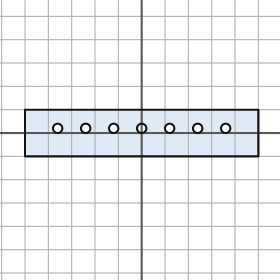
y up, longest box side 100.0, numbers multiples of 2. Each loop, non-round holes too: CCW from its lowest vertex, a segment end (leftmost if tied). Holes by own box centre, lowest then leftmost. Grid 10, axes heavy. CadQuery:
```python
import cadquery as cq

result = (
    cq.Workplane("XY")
    .moveTo(-50.0, -10.0)
    .lineTo(50.0, -10.0)
    .lineTo(50.0, 10.0)
    .lineTo(-50.0, 10.0)
    .close()
    .moveTo(-36.0, 2.0)
    .circle(2.0)
    .moveTo(-24.0, 2.0)
    .circle(2.0)
    .moveTo(-12.0, 2.0)
    .circle(2.0)
    .moveTo(0.0, 2.0)
    .circle(2.0)
    .moveTo(12.0, 2.0)
    .circle(2.0)
    .moveTo(24.0, 2.0)
    .circle(2.0)
    .moveTo(36.0, 2.0)
    .circle(2.0)
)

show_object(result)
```